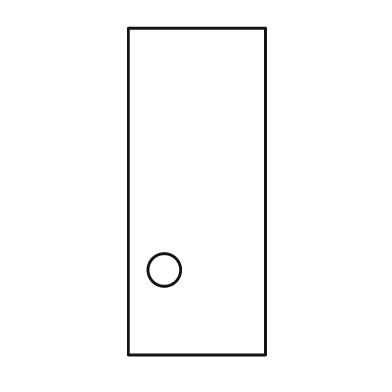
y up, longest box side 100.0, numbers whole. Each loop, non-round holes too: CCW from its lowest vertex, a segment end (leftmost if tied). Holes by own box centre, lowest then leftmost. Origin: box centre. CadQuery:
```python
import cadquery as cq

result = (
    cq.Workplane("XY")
    .moveTo(-21.0, -50.0)
    .lineTo(21.0, -50.0)
    .lineTo(21.0, 50.0)
    .lineTo(-21.0, 50.0)
    .close()
    .moveTo(-10.0, -24.0)
    .circle(5.0)
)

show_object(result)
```